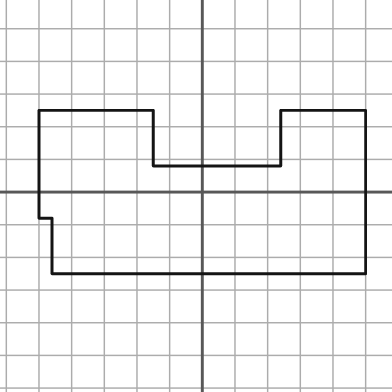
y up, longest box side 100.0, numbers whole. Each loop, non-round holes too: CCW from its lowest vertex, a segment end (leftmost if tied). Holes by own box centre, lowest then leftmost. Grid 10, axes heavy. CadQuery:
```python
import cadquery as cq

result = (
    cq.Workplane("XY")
    .moveTo(-46.0, -25.0)
    .lineTo(50.0, -25.0)
    .lineTo(50.0, 25.0)
    .lineTo(24.0, 25.0)
    .lineTo(24.0, 8.0)
    .lineTo(-15.0, 8.0)
    .lineTo(-15.0, 25.0)
    .lineTo(-50.0, 25.0)
    .lineTo(-50.0, -8.0)
    .lineTo(-46.0, -8.0)
    .close()
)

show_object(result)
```